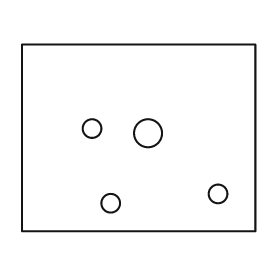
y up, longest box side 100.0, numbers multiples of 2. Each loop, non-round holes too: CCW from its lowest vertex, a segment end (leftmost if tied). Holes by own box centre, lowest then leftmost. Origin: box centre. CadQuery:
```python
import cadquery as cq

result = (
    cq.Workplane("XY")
    .moveTo(-50.0, -40.0)
    .lineTo(50.0, -40.0)
    .lineTo(50.0, 40.0)
    .lineTo(-50.0, 40.0)
    .close()
    .moveTo(-12.0, -28.0)
    .circle(4.0)
    .moveTo(34.0, -24.0)
    .circle(4.0)
    .moveTo(4.0, 2.0)
    .circle(6.0)
    .moveTo(-20.0, 4.0)
    .circle(4.0)
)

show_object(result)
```